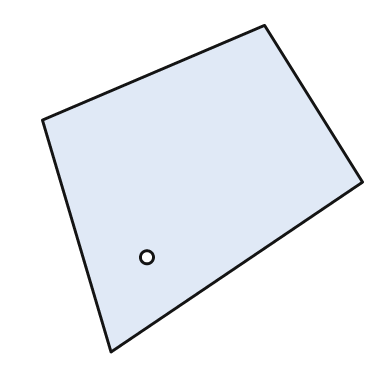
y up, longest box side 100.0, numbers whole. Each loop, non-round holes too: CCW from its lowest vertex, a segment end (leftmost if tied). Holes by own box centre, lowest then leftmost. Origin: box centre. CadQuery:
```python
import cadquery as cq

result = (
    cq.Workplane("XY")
    .moveTo(-28.0, -50.0)
    .lineTo(49.0, 2.0)
    .lineTo(19.0, 50.0)
    .lineTo(-49.0, 21.0)
    .close()
    .moveTo(-17.0, -21.0)
    .circle(2.0)
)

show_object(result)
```